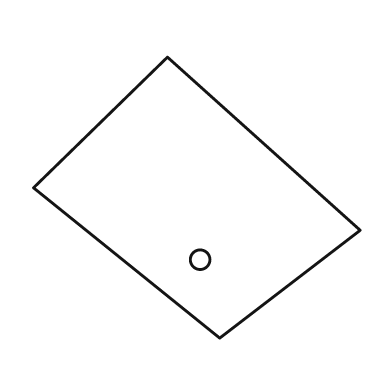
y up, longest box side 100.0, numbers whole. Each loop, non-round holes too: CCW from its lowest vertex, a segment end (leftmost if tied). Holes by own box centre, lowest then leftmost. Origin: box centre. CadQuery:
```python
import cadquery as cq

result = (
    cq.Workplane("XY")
    .moveTo(7.0, -43.0)
    .lineTo(50.0, -10.0)
    .lineTo(-9.0, 43.0)
    .lineTo(-50.0, 3.0)
    .close()
    .moveTo(1.0, -19.0)
    .circle(3.0)
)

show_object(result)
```